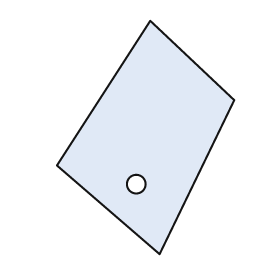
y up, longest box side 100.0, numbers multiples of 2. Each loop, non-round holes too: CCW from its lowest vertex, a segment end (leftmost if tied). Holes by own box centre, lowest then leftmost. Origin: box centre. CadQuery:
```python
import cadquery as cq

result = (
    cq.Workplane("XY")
    .moveTo(6.0, -50.0)
    .lineTo(38.0, 16.0)
    .lineTo(2.0, 50.0)
    .lineTo(-38.0, -12.0)
    .close()
    .moveTo(-4.0, -20.0)
    .circle(4.0)
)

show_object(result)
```